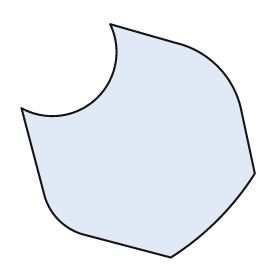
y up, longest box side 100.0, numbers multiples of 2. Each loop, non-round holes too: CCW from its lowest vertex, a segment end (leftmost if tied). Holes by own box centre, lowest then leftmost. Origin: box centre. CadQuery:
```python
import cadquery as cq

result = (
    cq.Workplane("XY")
    .moveTo(14.0, -50.0)
    .threePointArc((34.0, -34.0), (50.0, -14.0))
    .lineTo(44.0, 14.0)
    .threePointArc((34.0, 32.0), (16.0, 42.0))
    .lineTo(-12.0, 50.0)
    .threePointArc((-18.0, 18.0), (-50.0, 14.0))
    .lineTo(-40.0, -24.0)
    .threePointArc((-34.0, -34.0), (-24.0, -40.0))
    .close()
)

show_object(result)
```